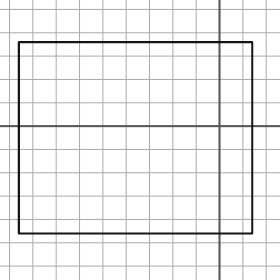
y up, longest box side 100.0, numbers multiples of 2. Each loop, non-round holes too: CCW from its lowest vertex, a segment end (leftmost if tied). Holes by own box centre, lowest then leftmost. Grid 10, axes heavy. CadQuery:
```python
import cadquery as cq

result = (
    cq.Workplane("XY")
    .moveTo(-86.0, -46.0)
    .lineTo(14.0, -46.0)
    .lineTo(14.0, 36.0)
    .lineTo(-86.0, 36.0)
    .close()
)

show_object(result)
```